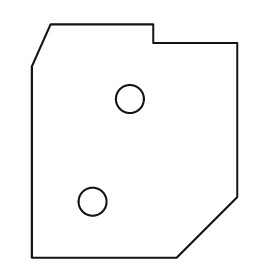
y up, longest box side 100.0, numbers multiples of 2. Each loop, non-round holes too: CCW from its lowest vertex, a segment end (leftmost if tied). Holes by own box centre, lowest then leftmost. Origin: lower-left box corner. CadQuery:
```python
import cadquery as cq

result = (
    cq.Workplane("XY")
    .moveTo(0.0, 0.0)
    .lineTo(62.0, 0.0)
    .lineTo(88.0, 26.0)
    .lineTo(88.0, 92.0)
    .lineTo(52.0, 92.0)
    .lineTo(52.0, 100.0)
    .lineTo(8.0, 100.0)
    .lineTo(0.0, 82.0)
    .close()
    .moveTo(26.0, 24.0)
    .circle(6.0)
    .moveTo(42.0, 68.0)
    .circle(6.0)
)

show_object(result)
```